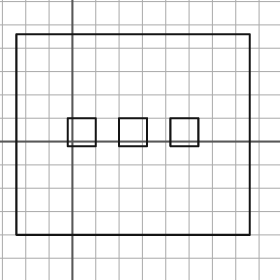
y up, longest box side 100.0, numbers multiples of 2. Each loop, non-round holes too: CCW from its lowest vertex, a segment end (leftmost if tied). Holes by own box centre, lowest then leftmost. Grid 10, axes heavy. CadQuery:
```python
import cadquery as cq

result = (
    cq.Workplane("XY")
    .moveTo(-24.0, -40.0)
    .lineTo(76.0, -40.0)
    .lineTo(76.0, 46.0)
    .lineTo(-24.0, 46.0)
    .close()
    .moveTo(-2.0, -2.0)
    .lineTo(10.0, -2.0)
    .lineTo(10.0, 10.0)
    .lineTo(-2.0, 10.0)
    .close()
    .moveTo(20.0, -2.0)
    .lineTo(32.0, -2.0)
    .lineTo(32.0, 10.0)
    .lineTo(20.0, 10.0)
    .close()
    .moveTo(42.0, -2.0)
    .lineTo(54.0, -2.0)
    .lineTo(54.0, 10.0)
    .lineTo(42.0, 10.0)
    .close()
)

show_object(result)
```